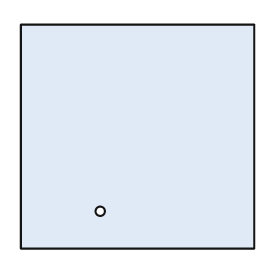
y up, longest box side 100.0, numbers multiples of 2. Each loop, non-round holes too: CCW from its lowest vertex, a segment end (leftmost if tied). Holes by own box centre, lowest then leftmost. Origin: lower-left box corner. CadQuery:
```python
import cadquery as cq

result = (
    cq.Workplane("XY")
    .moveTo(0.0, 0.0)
    .lineTo(100.0, 0.0)
    .lineTo(100.0, 96.0)
    .lineTo(0.0, 96.0)
    .close()
    .moveTo(34.0, 16.0)
    .circle(2.0)
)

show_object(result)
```